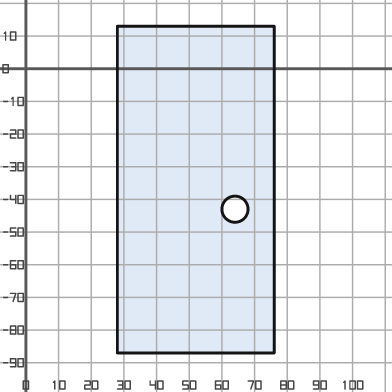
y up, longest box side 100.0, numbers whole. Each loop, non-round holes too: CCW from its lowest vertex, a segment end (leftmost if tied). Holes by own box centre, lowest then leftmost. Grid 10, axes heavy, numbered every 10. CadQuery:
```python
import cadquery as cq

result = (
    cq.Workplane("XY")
    .moveTo(28.0, -87.0)
    .lineTo(76.0, -87.0)
    .lineTo(76.0, 13.0)
    .lineTo(28.0, 13.0)
    .close()
    .moveTo(64.0, -43.0)
    .circle(4.0)
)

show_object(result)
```